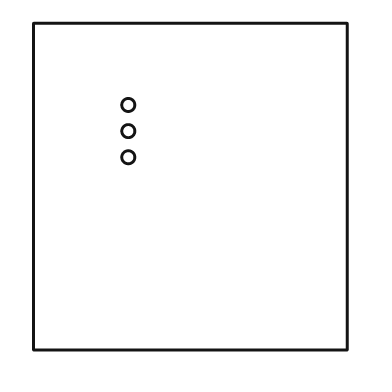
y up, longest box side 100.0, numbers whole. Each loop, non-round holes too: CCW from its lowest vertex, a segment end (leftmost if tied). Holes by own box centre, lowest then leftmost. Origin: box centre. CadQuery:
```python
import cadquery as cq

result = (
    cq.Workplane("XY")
    .moveTo(-48.0, -50.0)
    .lineTo(48.0, -50.0)
    .lineTo(48.0, 50.0)
    .lineTo(-48.0, 50.0)
    .close()
    .moveTo(-19.0, 9.0)
    .circle(2.0)
    .moveTo(-19.0, 17.0)
    .circle(2.0)
    .moveTo(-19.0, 25.0)
    .circle(2.0)
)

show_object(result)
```